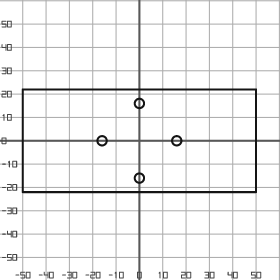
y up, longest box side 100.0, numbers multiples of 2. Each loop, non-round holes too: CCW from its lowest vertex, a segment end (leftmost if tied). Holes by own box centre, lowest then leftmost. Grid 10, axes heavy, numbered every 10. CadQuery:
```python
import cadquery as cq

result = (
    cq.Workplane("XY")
    .moveTo(-50.0, -22.0)
    .lineTo(50.0, -22.0)
    .lineTo(50.0, 22.0)
    .lineTo(-50.0, 22.0)
    .close()
    .moveTo(0.0, -16.0)
    .circle(2.0)
    .moveTo(-16.0, 0.0)
    .circle(2.0)
    .moveTo(16.0, 0.0)
    .circle(2.0)
    .moveTo(0.0, 16.0)
    .circle(2.0)
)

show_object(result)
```